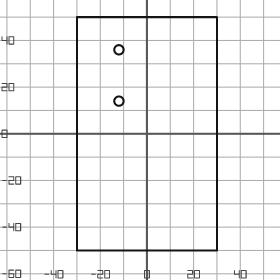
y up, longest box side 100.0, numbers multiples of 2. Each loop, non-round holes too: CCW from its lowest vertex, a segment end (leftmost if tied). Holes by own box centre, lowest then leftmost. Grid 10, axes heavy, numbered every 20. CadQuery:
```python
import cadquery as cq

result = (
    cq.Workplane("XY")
    .moveTo(-30.0, -50.0)
    .lineTo(30.0, -50.0)
    .lineTo(30.0, 50.0)
    .lineTo(-30.0, 50.0)
    .close()
    .moveTo(-12.0, 14.0)
    .circle(2.0)
    .moveTo(-12.0, 36.0)
    .circle(2.0)
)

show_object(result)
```